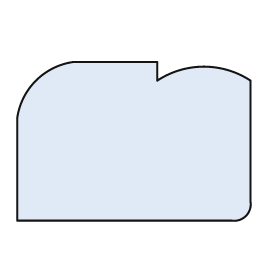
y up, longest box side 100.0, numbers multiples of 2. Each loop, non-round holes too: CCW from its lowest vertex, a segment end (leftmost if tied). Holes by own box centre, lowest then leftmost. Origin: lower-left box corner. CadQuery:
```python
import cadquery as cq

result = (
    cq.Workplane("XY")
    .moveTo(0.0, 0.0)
    .lineTo(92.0, 0.0)
    .threePointArc((98.0, 2.0), (100.0, 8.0))
    .lineTo(100.0, 60.0)
    .threePointArc((80.0, 66.0), (60.0, 60.0))
    .lineTo(60.0, 68.0)
    .lineTo(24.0, 68.0)
    .threePointArc((8.0, 60.0), (0.0, 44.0))
    .close()
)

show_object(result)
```